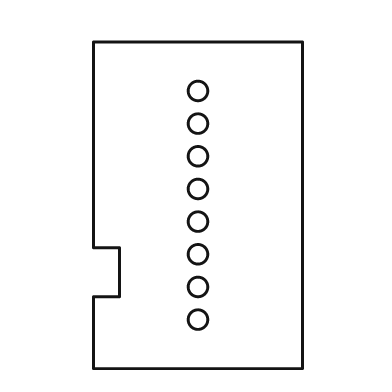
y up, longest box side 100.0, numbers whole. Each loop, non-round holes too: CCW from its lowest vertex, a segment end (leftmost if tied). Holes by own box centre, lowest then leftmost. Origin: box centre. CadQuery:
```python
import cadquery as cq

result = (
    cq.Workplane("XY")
    .moveTo(-32.0, -50.0)
    .lineTo(32.0, -50.0)
    .lineTo(32.0, 50.0)
    .lineTo(-32.0, 50.0)
    .lineTo(-32.0, -13.0)
    .lineTo(-24.0, -13.0)
    .lineTo(-24.0, -28.0)
    .lineTo(-32.0, -28.0)
    .close()
    .moveTo(0.0, -35.0)
    .circle(3.0)
    .moveTo(0.0, -25.0)
    .circle(3.0)
    .moveTo(0.0, -15.0)
    .circle(3.0)
    .moveTo(0.0, -5.0)
    .circle(3.0)
    .moveTo(0.0, 5.0)
    .circle(3.0)
    .moveTo(0.0, 15.0)
    .circle(3.0)
    .moveTo(0.0, 25.0)
    .circle(3.0)
    .moveTo(0.0, 35.0)
    .circle(3.0)
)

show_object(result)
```